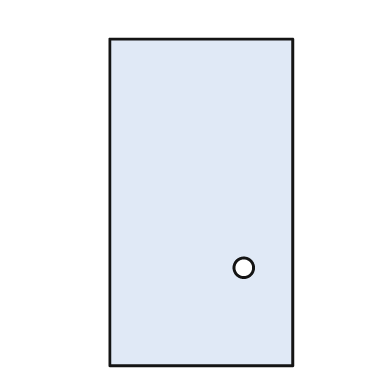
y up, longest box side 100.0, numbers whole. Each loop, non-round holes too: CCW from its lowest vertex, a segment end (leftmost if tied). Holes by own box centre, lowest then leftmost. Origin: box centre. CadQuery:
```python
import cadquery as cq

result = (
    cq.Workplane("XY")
    .moveTo(-28.0, -50.0)
    .lineTo(28.0, -50.0)
    .lineTo(28.0, 50.0)
    .lineTo(-28.0, 50.0)
    .close()
    .moveTo(13.0, -20.0)
    .circle(3.0)
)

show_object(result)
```